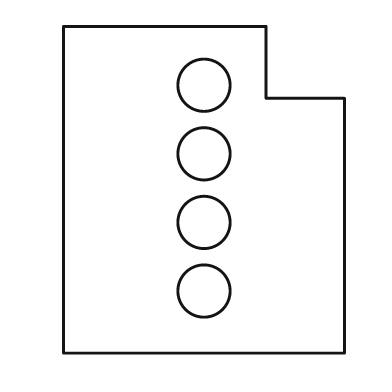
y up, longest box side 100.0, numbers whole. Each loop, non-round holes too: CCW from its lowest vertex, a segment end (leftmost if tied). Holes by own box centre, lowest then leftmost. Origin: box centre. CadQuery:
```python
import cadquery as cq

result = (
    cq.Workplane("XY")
    .moveTo(-43.0, -50.0)
    .lineTo(43.0, -50.0)
    .lineTo(43.0, 28.0)
    .lineTo(19.0, 28.0)
    .lineTo(19.0, 50.0)
    .lineTo(-43.0, 50.0)
    .close()
    .moveTo(0.0, -31.0)
    .circle(8.0)
    .moveTo(0.0, -10.0)
    .circle(8.0)
    .moveTo(0.0, 11.0)
    .circle(8.0)
    .moveTo(0.0, 32.0)
    .circle(8.0)
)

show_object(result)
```